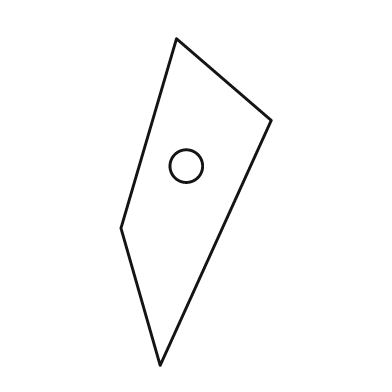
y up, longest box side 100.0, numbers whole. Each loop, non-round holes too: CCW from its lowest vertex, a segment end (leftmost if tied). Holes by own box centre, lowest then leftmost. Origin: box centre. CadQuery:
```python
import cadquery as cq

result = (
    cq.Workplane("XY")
    .moveTo(-11.0, -50.0)
    .lineTo(23.0, 25.0)
    .lineTo(-6.0, 50.0)
    .lineTo(-23.0, -8.0)
    .close()
    .moveTo(-3.0, 11.0)
    .circle(5.0)
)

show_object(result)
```